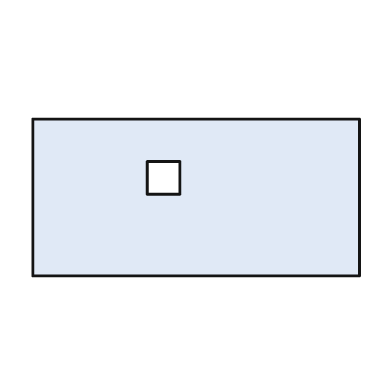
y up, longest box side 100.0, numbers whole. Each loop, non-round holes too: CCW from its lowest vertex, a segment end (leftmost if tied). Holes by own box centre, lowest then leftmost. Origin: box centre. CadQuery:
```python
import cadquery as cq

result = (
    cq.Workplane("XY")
    .moveTo(-50.0, -24.0)
    .lineTo(50.0, -24.0)
    .lineTo(50.0, 24.0)
    .lineTo(-50.0, 24.0)
    .close()
    .moveTo(-15.0, 1.0)
    .lineTo(-5.0, 1.0)
    .lineTo(-5.0, 11.0)
    .lineTo(-15.0, 11.0)
    .close()
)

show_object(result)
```